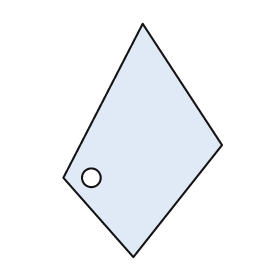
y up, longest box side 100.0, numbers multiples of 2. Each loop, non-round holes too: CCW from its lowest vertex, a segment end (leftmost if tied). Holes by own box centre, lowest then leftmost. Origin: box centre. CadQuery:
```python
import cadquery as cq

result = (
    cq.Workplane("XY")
    .moveTo(-4.0, -50.0)
    .lineTo(34.0, -2.0)
    .lineTo(0.0, 50.0)
    .lineTo(-34.0, -16.0)
    .close()
    .moveTo(-22.0, -16.0)
    .circle(4.0)
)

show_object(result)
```